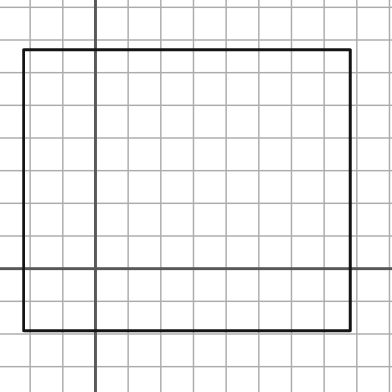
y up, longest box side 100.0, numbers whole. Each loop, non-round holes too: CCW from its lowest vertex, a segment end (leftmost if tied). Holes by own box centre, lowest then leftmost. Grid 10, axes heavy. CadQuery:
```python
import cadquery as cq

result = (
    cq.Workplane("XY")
    .moveTo(-22.0, -19.0)
    .lineTo(78.0, -19.0)
    .lineTo(78.0, 67.0)
    .lineTo(-22.0, 67.0)
    .close()
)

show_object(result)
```